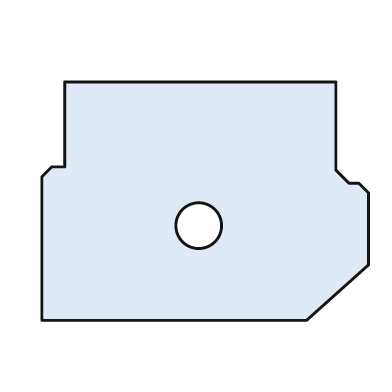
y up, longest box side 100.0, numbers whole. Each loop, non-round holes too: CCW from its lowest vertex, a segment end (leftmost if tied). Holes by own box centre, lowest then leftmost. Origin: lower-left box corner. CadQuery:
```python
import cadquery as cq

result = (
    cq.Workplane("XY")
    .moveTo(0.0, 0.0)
    .lineTo(81.0, 0.0)
    .lineTo(100.0, 17.0)
    .lineTo(100.0, 39.0)
    .lineTo(97.0, 42.0)
    .lineTo(94.0, 42.0)
    .lineTo(90.0, 46.0)
    .lineTo(90.0, 73.0)
    .lineTo(7.0, 73.0)
    .lineTo(7.0, 47.0)
    .lineTo(3.0, 47.0)
    .lineTo(0.0, 44.0)
    .close()
    .moveTo(48.0, 29.0)
    .circle(7.0)
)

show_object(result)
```